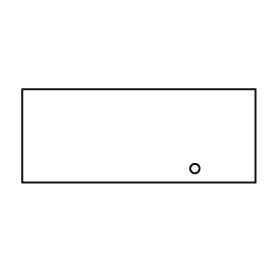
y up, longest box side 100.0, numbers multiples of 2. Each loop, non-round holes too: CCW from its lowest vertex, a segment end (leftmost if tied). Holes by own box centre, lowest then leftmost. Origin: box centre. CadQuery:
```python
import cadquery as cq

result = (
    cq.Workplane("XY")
    .moveTo(-50.0, -20.0)
    .lineTo(50.0, -20.0)
    .lineTo(50.0, 20.0)
    .lineTo(-50.0, 20.0)
    .close()
    .moveTo(24.0, -14.0)
    .circle(2.0)
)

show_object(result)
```